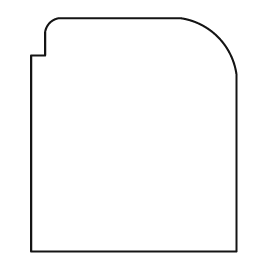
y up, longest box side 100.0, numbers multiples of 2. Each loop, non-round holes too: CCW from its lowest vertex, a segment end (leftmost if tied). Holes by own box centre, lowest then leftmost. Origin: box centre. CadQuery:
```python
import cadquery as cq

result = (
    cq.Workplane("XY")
    .moveTo(-44.0, -50.0)
    .lineTo(44.0, -50.0)
    .lineTo(44.0, 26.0)
    .threePointArc((36.0, 42.0), (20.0, 50.0))
    .lineTo(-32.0, 50.0)
    .threePointArc((-36.0, 48.0), (-38.0, 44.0))
    .lineTo(-38.0, 34.0)
    .lineTo(-44.0, 34.0)
    .close()
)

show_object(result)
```